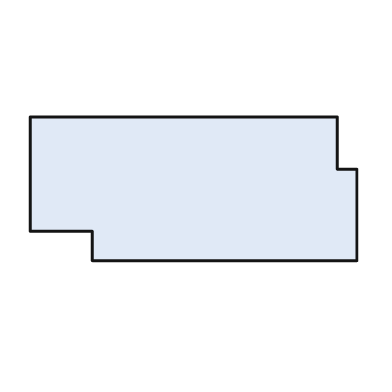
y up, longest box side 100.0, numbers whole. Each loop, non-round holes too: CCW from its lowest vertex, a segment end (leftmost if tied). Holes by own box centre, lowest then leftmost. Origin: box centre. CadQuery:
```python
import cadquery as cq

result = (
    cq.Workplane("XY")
    .moveTo(-31.0, -22.0)
    .lineTo(50.0, -22.0)
    .lineTo(50.0, 6.0)
    .lineTo(44.0, 6.0)
    .lineTo(44.0, 22.0)
    .lineTo(-50.0, 22.0)
    .lineTo(-50.0, -13.0)
    .lineTo(-31.0, -13.0)
    .close()
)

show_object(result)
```